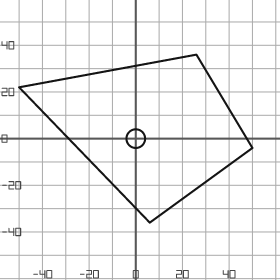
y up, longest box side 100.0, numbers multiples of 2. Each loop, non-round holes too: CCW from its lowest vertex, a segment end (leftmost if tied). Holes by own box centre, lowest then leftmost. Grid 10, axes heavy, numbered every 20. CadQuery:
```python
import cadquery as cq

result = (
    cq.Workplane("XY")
    .moveTo(6.0, -36.0)
    .lineTo(50.0, -4.0)
    .lineTo(26.0, 36.0)
    .lineTo(-50.0, 22.0)
    .close()
    .moveTo(0.0, 0.0)
    .circle(4.0)
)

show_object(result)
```